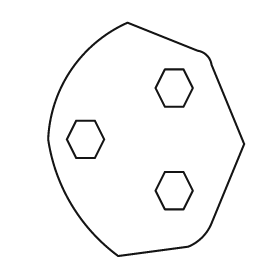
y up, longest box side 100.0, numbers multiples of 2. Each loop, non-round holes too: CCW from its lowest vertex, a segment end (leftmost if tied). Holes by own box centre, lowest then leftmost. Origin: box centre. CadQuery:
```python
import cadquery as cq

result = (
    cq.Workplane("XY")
    .moveTo(-12.0, -50.0)
    .lineTo(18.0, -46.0)
    .threePointArc((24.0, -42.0), (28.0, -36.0))
    .lineTo(42.0, -2.0)
    .lineTo(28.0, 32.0)
    .threePointArc((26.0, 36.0), (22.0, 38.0))
    .lineTo(-8.0, 50.0)
    .threePointArc((-32.0, 30.0), (-42.0, 0.0))
    .threePointArc((-32.0, -28.0), (-12.0, -50.0))
    .close()
    .moveTo(8.0, -30.0)
    .lineTo(16.0, -30.0)
    .lineTo(20.0, -22.0)
    .lineTo(16.0, -14.0)
    .lineTo(8.0, -14.0)
    .lineTo(4.0, -22.0)
    .close()
    .moveTo(-30.0, -8.0)
    .lineTo(-22.0, -8.0)
    .lineTo(-18.0, 0.0)
    .lineTo(-22.0, 8.0)
    .lineTo(-30.0, 8.0)
    .lineTo(-34.0, 0.0)
    .close()
    .moveTo(8.0, 14.0)
    .lineTo(16.0, 14.0)
    .lineTo(20.0, 22.0)
    .lineTo(16.0, 30.0)
    .lineTo(8.0, 30.0)
    .lineTo(4.0, 22.0)
    .close()
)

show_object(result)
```